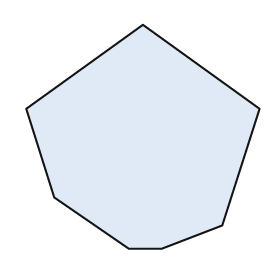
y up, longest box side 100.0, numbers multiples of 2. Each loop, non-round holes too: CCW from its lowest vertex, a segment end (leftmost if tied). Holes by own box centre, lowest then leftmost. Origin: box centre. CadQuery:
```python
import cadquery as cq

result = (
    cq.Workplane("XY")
    .moveTo(-6.0, -48.0)
    .lineTo(8.0, -48.0)
    .lineTo(34.0, -38.0)
    .lineTo(50.0, 12.0)
    .lineTo(0.0, 48.0)
    .lineTo(-50.0, 12.0)
    .lineTo(-38.0, -26.0)
    .close()
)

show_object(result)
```